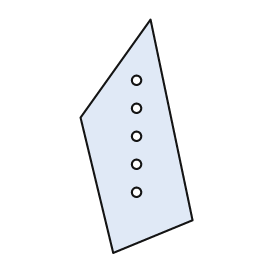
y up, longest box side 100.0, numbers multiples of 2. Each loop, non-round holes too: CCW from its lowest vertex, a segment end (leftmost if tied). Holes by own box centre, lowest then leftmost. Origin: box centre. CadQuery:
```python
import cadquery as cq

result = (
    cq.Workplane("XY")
    .moveTo(-10.0, -50.0)
    .lineTo(24.0, -36.0)
    .lineTo(6.0, 50.0)
    .lineTo(-24.0, 8.0)
    .close()
    .moveTo(0.0, -24.0)
    .circle(2.0)
    .moveTo(0.0, -12.0)
    .circle(2.0)
    .moveTo(0.0, 0.0)
    .circle(2.0)
    .moveTo(0.0, 12.0)
    .circle(2.0)
    .moveTo(0.0, 24.0)
    .circle(2.0)
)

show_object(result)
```